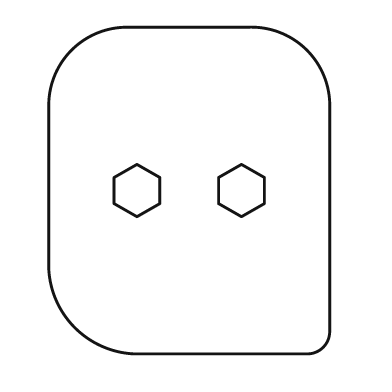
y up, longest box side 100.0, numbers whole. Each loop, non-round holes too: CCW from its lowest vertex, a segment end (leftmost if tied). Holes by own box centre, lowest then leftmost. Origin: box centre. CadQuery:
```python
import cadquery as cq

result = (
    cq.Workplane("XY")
    .moveTo(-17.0, -50.0)
    .lineTo(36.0, -50.0)
    .threePointArc((41.0, -48.0), (43.0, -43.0))
    .lineTo(43.0, 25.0)
    .threePointArc((36.0, 43.0), (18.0, 50.0))
    .lineTo(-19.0, 50.0)
    .threePointArc((-36.0, 43.0), (-43.0, 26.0))
    .lineTo(-43.0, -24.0)
    .threePointArc((-35.0, -42.0), (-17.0, -50.0))
    .close()
    .moveTo(-16.0, -8.0)
    .lineTo(-9.0, -4.0)
    .lineTo(-9.0, 4.0)
    .lineTo(-16.0, 8.0)
    .lineTo(-23.0, 4.0)
    .lineTo(-23.0, -4.0)
    .close()
    .moveTo(16.0, -8.0)
    .lineTo(23.0, -4.0)
    .lineTo(23.0, 4.0)
    .lineTo(16.0, 8.0)
    .lineTo(9.0, 4.0)
    .lineTo(9.0, -4.0)
    .close()
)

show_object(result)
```